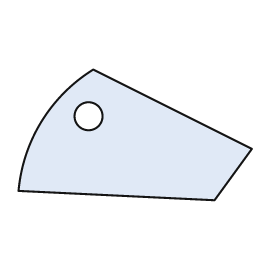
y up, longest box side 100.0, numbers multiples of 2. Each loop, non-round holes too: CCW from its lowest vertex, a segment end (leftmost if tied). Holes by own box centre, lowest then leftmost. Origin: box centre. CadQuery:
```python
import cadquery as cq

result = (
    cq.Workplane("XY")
    .moveTo(34.0, -28.0)
    .lineTo(50.0, -6.0)
    .lineTo(-18.0, 28.0)
    .threePointArc((-40.0, 6.0), (-50.0, -24.0))
    .close()
    .moveTo(-20.0, 8.0)
    .circle(6.0)
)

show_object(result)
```